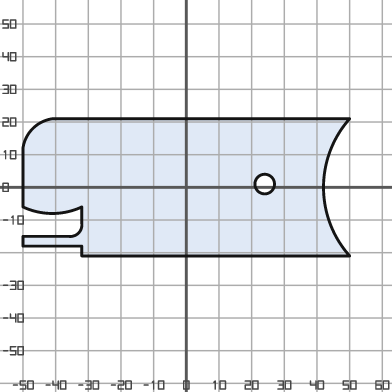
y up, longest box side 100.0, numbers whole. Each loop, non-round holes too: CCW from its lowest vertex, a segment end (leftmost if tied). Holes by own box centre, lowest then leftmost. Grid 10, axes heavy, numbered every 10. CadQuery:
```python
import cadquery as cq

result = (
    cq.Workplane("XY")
    .moveTo(-32.0, -21.0)
    .lineTo(50.0, -21.0)
    .threePointArc((42.0, 0.0), (50.0, 21.0))
    .lineTo(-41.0, 21.0)
    .threePointArc((-47.0, 18.0), (-50.0, 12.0))
    .lineTo(-50.0, -6.0)
    .threePointArc((-41.0, -8.0), (-32.0, -6.0))
    .lineTo(-32.0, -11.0)
    .threePointArc((-33.0, -14.0), (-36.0, -15.0))
    .lineTo(-50.0, -15.0)
    .lineTo(-50.0, -18.0)
    .lineTo(-32.0, -18.0)
    .close()
    .moveTo(24.0, 1.0)
    .circle(3.0)
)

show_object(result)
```